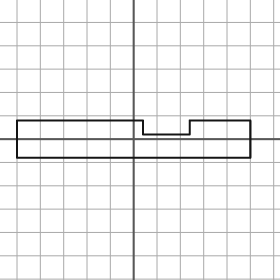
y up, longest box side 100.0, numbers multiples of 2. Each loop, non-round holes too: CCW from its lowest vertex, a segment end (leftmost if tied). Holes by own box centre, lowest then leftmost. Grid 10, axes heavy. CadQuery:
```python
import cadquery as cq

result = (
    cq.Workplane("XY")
    .moveTo(-50.0, -8.0)
    .lineTo(50.0, -8.0)
    .lineTo(50.0, 8.0)
    .lineTo(24.0, 8.0)
    .lineTo(24.0, 2.0)
    .lineTo(4.0, 2.0)
    .lineTo(4.0, 8.0)
    .lineTo(-50.0, 8.0)
    .close()
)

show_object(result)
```